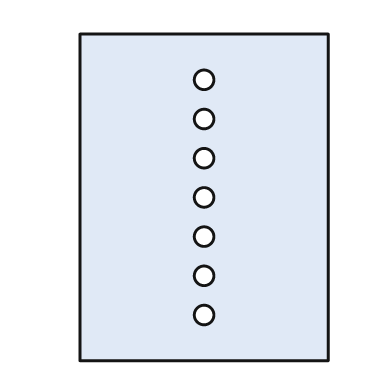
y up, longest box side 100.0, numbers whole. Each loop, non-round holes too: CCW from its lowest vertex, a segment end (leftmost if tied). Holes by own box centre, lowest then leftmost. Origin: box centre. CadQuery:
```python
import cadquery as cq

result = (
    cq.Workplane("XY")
    .moveTo(-38.0, -50.0)
    .lineTo(38.0, -50.0)
    .lineTo(38.0, 50.0)
    .lineTo(-38.0, 50.0)
    .close()
    .moveTo(0.0, -36.0)
    .circle(3.0)
    .moveTo(0.0, -24.0)
    .circle(3.0)
    .moveTo(0.0, -12.0)
    .circle(3.0)
    .moveTo(0.0, 0.0)
    .circle(3.0)
    .moveTo(0.0, 12.0)
    .circle(3.0)
    .moveTo(0.0, 24.0)
    .circle(3.0)
    .moveTo(0.0, 36.0)
    .circle(3.0)
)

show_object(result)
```